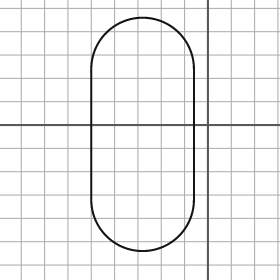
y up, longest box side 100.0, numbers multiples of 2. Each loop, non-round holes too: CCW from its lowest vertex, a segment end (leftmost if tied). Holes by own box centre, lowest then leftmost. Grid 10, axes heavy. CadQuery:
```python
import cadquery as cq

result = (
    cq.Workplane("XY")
    .moveTo(-50.0, -32.0)
    .threePointArc((-28.0, -54.0), (-6.0, -32.0))
    .lineTo(-6.0, 24.0)
    .threePointArc((-28.0, 46.0), (-50.0, 24.0))
    .close()
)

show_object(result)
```